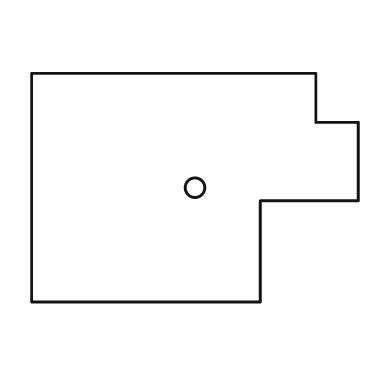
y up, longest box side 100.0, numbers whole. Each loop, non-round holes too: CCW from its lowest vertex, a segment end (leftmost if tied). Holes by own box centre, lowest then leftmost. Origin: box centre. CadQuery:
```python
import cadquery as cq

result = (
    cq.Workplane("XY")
    .moveTo(-50.0, -35.0)
    .lineTo(20.0, -35.0)
    .lineTo(20.0, -4.0)
    .lineTo(50.0, -4.0)
    .lineTo(50.0, 20.0)
    .lineTo(37.0, 20.0)
    .lineTo(37.0, 35.0)
    .lineTo(-50.0, 35.0)
    .close()
    .moveTo(0.0, 0.0)
    .circle(3.0)
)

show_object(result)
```